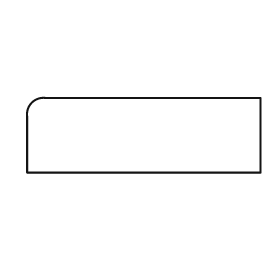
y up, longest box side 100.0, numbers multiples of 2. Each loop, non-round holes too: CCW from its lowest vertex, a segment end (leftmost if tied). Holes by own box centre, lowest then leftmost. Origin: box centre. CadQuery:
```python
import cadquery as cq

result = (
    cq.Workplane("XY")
    .moveTo(-50.0, -16.0)
    .lineTo(50.0, -16.0)
    .lineTo(50.0, 16.0)
    .lineTo(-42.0, 16.0)
    .threePointArc((-48.0, 14.0), (-50.0, 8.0))
    .close()
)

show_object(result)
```